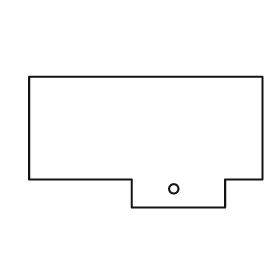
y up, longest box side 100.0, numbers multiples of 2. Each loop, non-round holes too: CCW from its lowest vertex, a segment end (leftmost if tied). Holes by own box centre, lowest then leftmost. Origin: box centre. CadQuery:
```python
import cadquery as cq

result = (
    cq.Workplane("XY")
    .moveTo(-6.0, -28.0)
    .lineTo(34.0, -28.0)
    .lineTo(34.0, -16.0)
    .lineTo(50.0, -16.0)
    .lineTo(50.0, 28.0)
    .lineTo(-50.0, 28.0)
    .lineTo(-50.0, -16.0)
    .lineTo(-6.0, -16.0)
    .close()
    .moveTo(12.0, -20.0)
    .circle(2.0)
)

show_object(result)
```